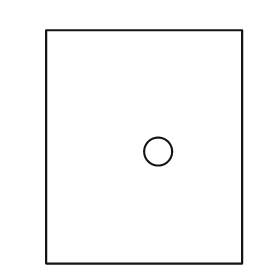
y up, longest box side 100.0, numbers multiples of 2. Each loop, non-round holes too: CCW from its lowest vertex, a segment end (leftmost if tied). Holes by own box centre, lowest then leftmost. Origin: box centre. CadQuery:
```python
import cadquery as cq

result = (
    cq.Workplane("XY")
    .moveTo(-42.0, -50.0)
    .lineTo(42.0, -50.0)
    .lineTo(42.0, 50.0)
    .lineTo(-42.0, 50.0)
    .close()
    .moveTo(6.0, -2.0)
    .circle(6.0)
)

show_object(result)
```